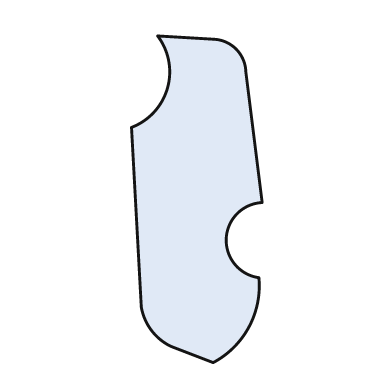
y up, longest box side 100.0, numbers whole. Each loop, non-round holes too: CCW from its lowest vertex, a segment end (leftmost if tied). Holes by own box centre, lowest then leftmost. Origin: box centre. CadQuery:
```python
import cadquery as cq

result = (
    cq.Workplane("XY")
    .moveTo(5.0, -50.0)
    .threePointArc((16.0, -39.0), (19.0, -24.0))
    .threePointArc((9.0, -12.0), (20.0, -1.0))
    .lineTo(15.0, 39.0)
    .threePointArc((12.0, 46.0), (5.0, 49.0))
    .lineTo(-12.0, 50.0)
    .threePointArc((-9.0, 34.0), (-20.0, 22.0))
    .lineTo(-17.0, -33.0)
    .threePointArc((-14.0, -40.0), (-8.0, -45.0))
    .close()
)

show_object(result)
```